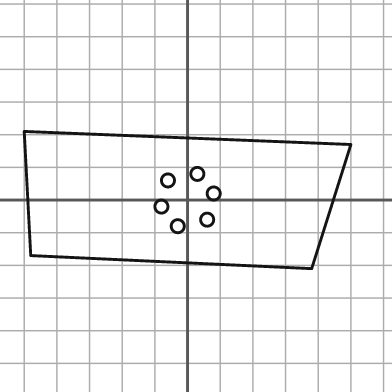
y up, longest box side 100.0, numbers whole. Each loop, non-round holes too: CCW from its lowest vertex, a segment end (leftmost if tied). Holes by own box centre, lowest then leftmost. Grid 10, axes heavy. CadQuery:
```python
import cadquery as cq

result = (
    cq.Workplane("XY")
    .moveTo(38.0, -21.0)
    .lineTo(50.0, 17.0)
    .lineTo(-50.0, 21.0)
    .lineTo(-48.0, -17.0)
    .close()
    .moveTo(-3.0, -8.0)
    .circle(2.0)
    .moveTo(6.0, -6.0)
    .circle(2.0)
    .moveTo(-8.0, -2.0)
    .circle(2.0)
    .moveTo(8.0, 2.0)
    .circle(2.0)
    .moveTo(-6.0, 6.0)
    .circle(2.0)
    .moveTo(3.0, 8.0)
    .circle(2.0)
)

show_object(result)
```